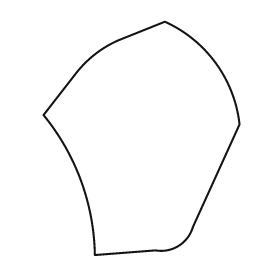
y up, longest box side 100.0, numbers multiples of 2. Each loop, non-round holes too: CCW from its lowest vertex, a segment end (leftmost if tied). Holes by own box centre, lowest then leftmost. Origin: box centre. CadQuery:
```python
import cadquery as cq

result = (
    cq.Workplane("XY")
    .moveTo(-20.0, -50.0)
    .lineTo(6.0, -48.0)
    .threePointArc((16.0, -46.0), (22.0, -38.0))
    .lineTo(42.0, 6.0)
    .threePointArc((32.0, 32.0), (10.0, 50.0))
    .lineTo(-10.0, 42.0)
    .threePointArc((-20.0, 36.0), (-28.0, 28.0))
    .lineTo(-42.0, 10.0)
    .threePointArc((-26.0, -18.0), (-20.0, -50.0))
    .close()
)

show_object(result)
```